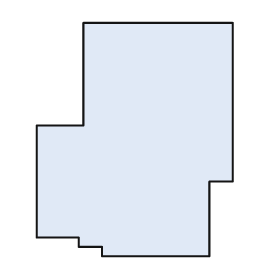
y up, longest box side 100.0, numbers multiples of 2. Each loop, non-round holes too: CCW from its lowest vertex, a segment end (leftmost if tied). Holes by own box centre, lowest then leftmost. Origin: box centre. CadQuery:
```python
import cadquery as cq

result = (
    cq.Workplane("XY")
    .moveTo(-14.0, -50.0)
    .lineTo(32.0, -50.0)
    .lineTo(32.0, -18.0)
    .lineTo(42.0, -18.0)
    .lineTo(42.0, 50.0)
    .lineTo(-22.0, 50.0)
    .lineTo(-22.0, 6.0)
    .lineTo(-42.0, 6.0)
    .lineTo(-42.0, -42.0)
    .lineTo(-24.0, -42.0)
    .lineTo(-24.0, -46.0)
    .lineTo(-14.0, -46.0)
    .close()
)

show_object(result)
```